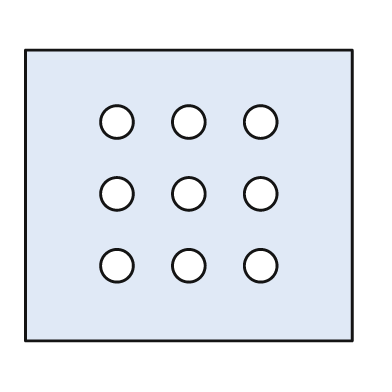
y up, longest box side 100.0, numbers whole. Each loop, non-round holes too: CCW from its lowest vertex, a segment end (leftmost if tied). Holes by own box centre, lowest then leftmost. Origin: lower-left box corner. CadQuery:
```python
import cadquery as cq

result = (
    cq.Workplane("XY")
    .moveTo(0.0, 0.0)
    .lineTo(100.0, 0.0)
    .lineTo(100.0, 89.0)
    .lineTo(0.0, 89.0)
    .close()
    .moveTo(28.0, 23.0)
    .circle(5.0)
    .moveTo(50.0, 23.0)
    .circle(5.0)
    .moveTo(72.0, 23.0)
    .circle(5.0)
    .moveTo(28.0, 45.0)
    .circle(5.0)
    .moveTo(50.0, 45.0)
    .circle(5.0)
    .moveTo(72.0, 45.0)
    .circle(5.0)
    .moveTo(28.0, 67.0)
    .circle(5.0)
    .moveTo(50.0, 67.0)
    .circle(5.0)
    .moveTo(72.0, 67.0)
    .circle(5.0)
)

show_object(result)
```